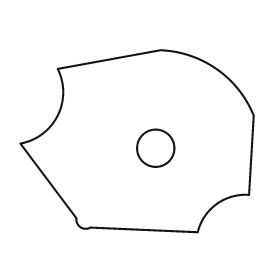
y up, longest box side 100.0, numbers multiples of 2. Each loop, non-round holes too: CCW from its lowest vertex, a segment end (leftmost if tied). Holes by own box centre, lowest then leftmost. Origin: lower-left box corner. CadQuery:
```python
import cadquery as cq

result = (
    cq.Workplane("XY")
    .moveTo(76.0, 0.0)
    .threePointArc((84.0, 12.0), (98.0, 16.0))
    .lineTo(100.0, 50.0)
    .threePointArc((84.0, 70.0), (60.0, 78.0))
    .lineTo(16.0, 70.0)
    .threePointArc((16.0, 50.0), (0.0, 38.0))
    .lineTo(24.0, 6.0)
    .threePointArc((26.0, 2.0), (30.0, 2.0))
    .close()
    .moveTo(58.0, 36.0)
    .circle(8.0)
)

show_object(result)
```